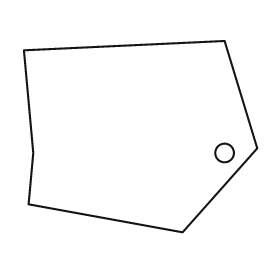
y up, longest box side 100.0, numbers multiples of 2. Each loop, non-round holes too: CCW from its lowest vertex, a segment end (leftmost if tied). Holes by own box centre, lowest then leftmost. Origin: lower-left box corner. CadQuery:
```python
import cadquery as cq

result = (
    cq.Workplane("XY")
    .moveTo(68.0, 0.0)
    .lineTo(100.0, 36.0)
    .lineTo(86.0, 82.0)
    .lineTo(0.0, 78.0)
    .lineTo(4.0, 34.0)
    .lineTo(2.0, 12.0)
    .close()
    .moveTo(86.0, 34.0)
    .circle(4.0)
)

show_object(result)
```